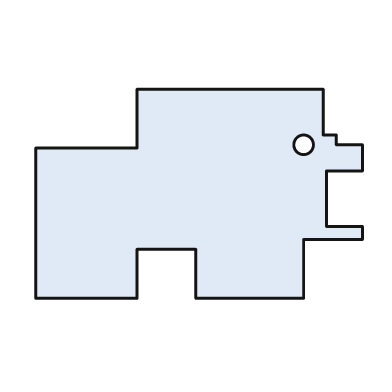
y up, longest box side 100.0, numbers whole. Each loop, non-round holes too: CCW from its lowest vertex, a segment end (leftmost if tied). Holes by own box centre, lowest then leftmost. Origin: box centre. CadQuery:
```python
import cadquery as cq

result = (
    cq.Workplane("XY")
    .moveTo(-50.0, -32.0)
    .lineTo(-19.0, -32.0)
    .lineTo(-19.0, -17.0)
    .lineTo(-1.0, -17.0)
    .lineTo(-1.0, -32.0)
    .lineTo(32.0, -32.0)
    .lineTo(32.0, -14.0)
    .lineTo(50.0, -14.0)
    .lineTo(50.0, -10.0)
    .lineTo(39.0, -10.0)
    .lineTo(39.0, 7.0)
    .lineTo(50.0, 7.0)
    .lineTo(50.0, 15.0)
    .lineTo(42.0, 15.0)
    .lineTo(42.0, 18.0)
    .lineTo(38.0, 18.0)
    .lineTo(38.0, 32.0)
    .lineTo(-19.0, 32.0)
    .lineTo(-19.0, 14.0)
    .lineTo(-50.0, 14.0)
    .close()
    .moveTo(32.0, 15.0)
    .circle(3.0)
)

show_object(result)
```